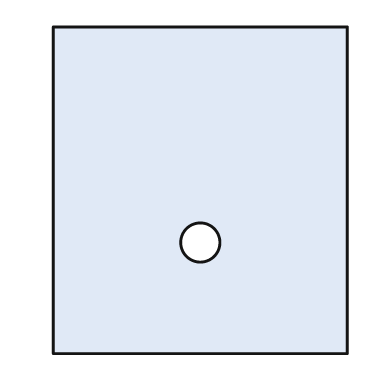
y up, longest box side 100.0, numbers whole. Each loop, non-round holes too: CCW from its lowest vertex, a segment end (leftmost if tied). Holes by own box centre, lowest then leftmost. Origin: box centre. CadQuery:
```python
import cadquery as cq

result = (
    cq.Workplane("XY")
    .moveTo(-45.0, -50.0)
    .lineTo(45.0, -50.0)
    .lineTo(45.0, 50.0)
    .lineTo(-45.0, 50.0)
    .close()
    .moveTo(0.0, -16.0)
    .circle(6.0)
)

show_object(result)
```